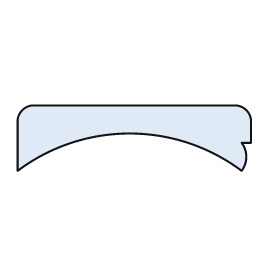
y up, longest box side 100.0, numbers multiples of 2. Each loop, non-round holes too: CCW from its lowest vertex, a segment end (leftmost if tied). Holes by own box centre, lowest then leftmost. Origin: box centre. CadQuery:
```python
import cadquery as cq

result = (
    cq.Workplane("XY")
    .moveTo(-50.0, -14.0)
    .threePointArc((-2.0, 2.0), (46.0, -14.0))
    .threePointArc((48.0, -8.0), (46.0, -2.0))
    .lineTo(50.0, -2.0)
    .lineTo(50.0, 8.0)
    .threePointArc((48.0, 12.0), (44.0, 14.0))
    .lineTo(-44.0, 14.0)
    .threePointArc((-48.0, 12.0), (-50.0, 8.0))
    .close()
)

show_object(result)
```